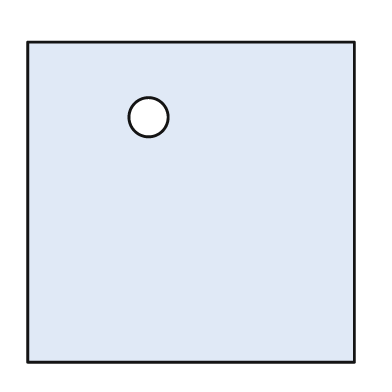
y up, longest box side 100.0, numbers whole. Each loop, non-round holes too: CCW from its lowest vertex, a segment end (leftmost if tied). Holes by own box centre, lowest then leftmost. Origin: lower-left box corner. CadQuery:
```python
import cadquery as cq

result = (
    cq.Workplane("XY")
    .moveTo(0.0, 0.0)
    .lineTo(100.0, 0.0)
    .lineTo(100.0, 98.0)
    .lineTo(0.0, 98.0)
    .close()
    .moveTo(37.0, 75.0)
    .circle(6.0)
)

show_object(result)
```